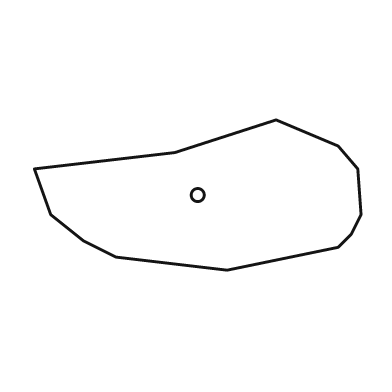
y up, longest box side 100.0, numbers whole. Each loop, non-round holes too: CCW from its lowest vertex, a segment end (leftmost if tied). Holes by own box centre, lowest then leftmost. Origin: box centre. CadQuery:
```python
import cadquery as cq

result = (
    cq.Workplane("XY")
    .moveTo(9.0, -23.0)
    .lineTo(43.0, -16.0)
    .lineTo(47.0, -12.0)
    .lineTo(50.0, -6.0)
    .lineTo(49.0, 8.0)
    .lineTo(43.0, 15.0)
    .lineTo(24.0, 23.0)
    .lineTo(-7.0, 13.0)
    .lineTo(-50.0, 8.0)
    .lineTo(-45.0, -6.0)
    .lineTo(-35.0, -14.0)
    .lineTo(-25.0, -19.0)
    .close()
    .moveTo(0.0, 0.0)
    .circle(2.0)
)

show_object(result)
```